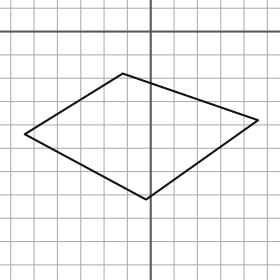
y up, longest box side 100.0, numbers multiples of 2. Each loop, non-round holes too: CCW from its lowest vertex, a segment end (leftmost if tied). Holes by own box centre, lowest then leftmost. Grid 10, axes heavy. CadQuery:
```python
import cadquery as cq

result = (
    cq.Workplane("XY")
    .moveTo(-2.0, -72.0)
    .lineTo(46.0, -38.0)
    .lineTo(-12.0, -18.0)
    .lineTo(-54.0, -44.0)
    .close()
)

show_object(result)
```